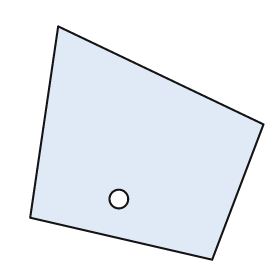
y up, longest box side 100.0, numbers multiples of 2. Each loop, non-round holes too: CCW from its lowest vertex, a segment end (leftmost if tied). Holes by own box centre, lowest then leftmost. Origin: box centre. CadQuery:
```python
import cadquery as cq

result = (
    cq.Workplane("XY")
    .moveTo(28.0, -50.0)
    .lineTo(50.0, 8.0)
    .lineTo(-38.0, 50.0)
    .lineTo(-50.0, -32.0)
    .close()
    .moveTo(-12.0, -24.0)
    .circle(4.0)
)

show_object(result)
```